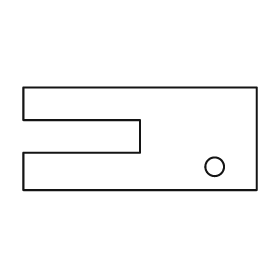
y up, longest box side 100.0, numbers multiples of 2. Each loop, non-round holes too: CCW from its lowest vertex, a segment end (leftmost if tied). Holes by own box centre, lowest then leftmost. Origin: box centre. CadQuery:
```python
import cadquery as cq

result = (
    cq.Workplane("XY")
    .moveTo(-50.0, -22.0)
    .lineTo(50.0, -22.0)
    .lineTo(50.0, 22.0)
    .lineTo(-50.0, 22.0)
    .lineTo(-50.0, 8.0)
    .lineTo(0.0, 8.0)
    .lineTo(0.0, -6.0)
    .lineTo(-50.0, -6.0)
    .close()
    .moveTo(32.0, -12.0)
    .circle(4.0)
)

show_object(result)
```